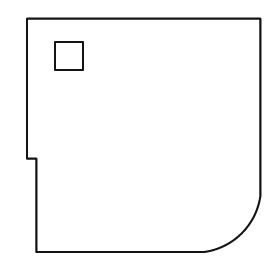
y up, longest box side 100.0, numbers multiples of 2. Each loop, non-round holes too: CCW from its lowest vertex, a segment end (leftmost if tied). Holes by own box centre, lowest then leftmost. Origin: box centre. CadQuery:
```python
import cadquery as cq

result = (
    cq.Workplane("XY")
    .moveTo(-46.0, -50.0)
    .lineTo(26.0, -50.0)
    .threePointArc((42.0, -42.0), (50.0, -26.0))
    .lineTo(50.0, 50.0)
    .lineTo(-50.0, 50.0)
    .lineTo(-50.0, -10.0)
    .lineTo(-46.0, -10.0)
    .close()
    .moveTo(-38.0, 28.0)
    .lineTo(-26.0, 28.0)
    .lineTo(-26.0, 40.0)
    .lineTo(-38.0, 40.0)
    .close()
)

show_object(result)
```